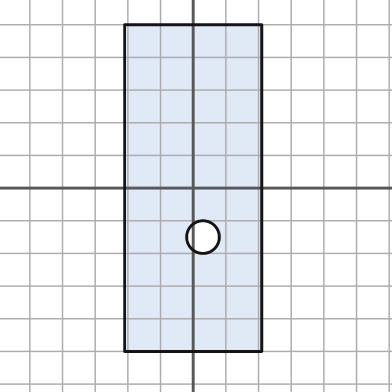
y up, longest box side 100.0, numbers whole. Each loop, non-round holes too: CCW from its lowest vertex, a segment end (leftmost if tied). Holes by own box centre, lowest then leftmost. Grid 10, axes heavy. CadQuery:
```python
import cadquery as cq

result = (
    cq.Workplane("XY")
    .moveTo(-21.0, -50.0)
    .lineTo(21.0, -50.0)
    .lineTo(21.0, 50.0)
    .lineTo(-21.0, 50.0)
    .close()
    .moveTo(3.0, -15.0)
    .circle(5.0)
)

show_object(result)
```